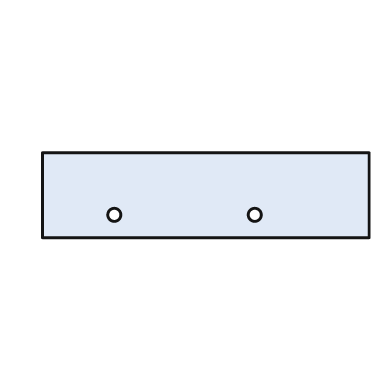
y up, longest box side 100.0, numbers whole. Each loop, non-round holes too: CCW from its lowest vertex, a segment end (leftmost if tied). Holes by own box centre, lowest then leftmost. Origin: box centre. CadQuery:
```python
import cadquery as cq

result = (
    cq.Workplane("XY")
    .moveTo(-50.0, -13.0)
    .lineTo(50.0, -13.0)
    .lineTo(50.0, 13.0)
    .lineTo(-50.0, 13.0)
    .close()
    .moveTo(-28.0, -6.0)
    .circle(2.0)
    .moveTo(15.0, -6.0)
    .circle(2.0)
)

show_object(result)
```